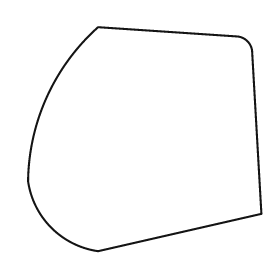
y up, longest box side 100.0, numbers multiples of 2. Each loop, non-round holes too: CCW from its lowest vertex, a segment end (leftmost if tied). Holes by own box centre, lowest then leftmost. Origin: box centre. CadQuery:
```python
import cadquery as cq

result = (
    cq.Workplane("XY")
    .moveTo(-20.0, -48.0)
    .lineTo(50.0, -32.0)
    .lineTo(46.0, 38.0)
    .threePointArc((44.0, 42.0), (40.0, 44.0))
    .lineTo(-20.0, 48.0)
    .threePointArc((-42.0, 18.0), (-50.0, -18.0))
    .threePointArc((-40.0, -38.0), (-20.0, -48.0))
    .close()
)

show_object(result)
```